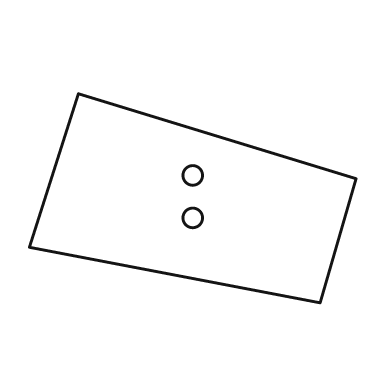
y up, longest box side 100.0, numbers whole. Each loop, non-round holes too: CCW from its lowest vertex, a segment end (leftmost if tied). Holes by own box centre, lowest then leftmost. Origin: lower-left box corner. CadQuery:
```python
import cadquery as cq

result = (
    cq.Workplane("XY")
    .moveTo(89.0, 0.0)
    .lineTo(100.0, 38.0)
    .lineTo(15.0, 64.0)
    .lineTo(0.0, 17.0)
    .close()
    .moveTo(50.0, 26.0)
    .circle(3.0)
    .moveTo(50.0, 39.0)
    .circle(3.0)
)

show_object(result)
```